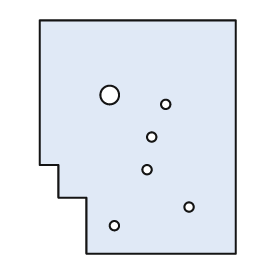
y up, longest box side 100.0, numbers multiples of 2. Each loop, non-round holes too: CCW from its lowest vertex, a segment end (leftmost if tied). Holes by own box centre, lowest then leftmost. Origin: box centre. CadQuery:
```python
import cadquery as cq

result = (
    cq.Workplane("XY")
    .moveTo(-22.0, -50.0)
    .lineTo(42.0, -50.0)
    .lineTo(42.0, 50.0)
    .lineTo(-42.0, 50.0)
    .lineTo(-42.0, -12.0)
    .lineTo(-34.0, -12.0)
    .lineTo(-34.0, -26.0)
    .lineTo(-22.0, -26.0)
    .close()
    .moveTo(-10.0, -38.0)
    .circle(2.0)
    .moveTo(22.0, -30.0)
    .circle(2.0)
    .moveTo(4.0, -14.0)
    .circle(2.0)
    .moveTo(6.0, 0.0)
    .circle(2.0)
    .moveTo(12.0, 14.0)
    .circle(2.0)
    .moveTo(-12.0, 18.0)
    .circle(4.0)
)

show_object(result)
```